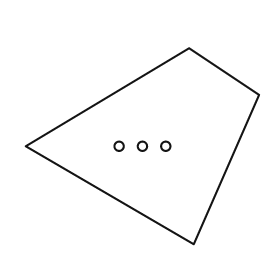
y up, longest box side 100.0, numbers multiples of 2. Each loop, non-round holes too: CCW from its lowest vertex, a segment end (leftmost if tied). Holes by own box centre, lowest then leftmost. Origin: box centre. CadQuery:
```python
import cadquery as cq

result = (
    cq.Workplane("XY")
    .moveTo(22.0, -42.0)
    .lineTo(50.0, 22.0)
    .lineTo(20.0, 42.0)
    .lineTo(-50.0, 0.0)
    .close()
    .moveTo(-10.0, 0.0)
    .circle(2.0)
    .moveTo(0.0, 0.0)
    .circle(2.0)
    .moveTo(10.0, 0.0)
    .circle(2.0)
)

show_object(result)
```